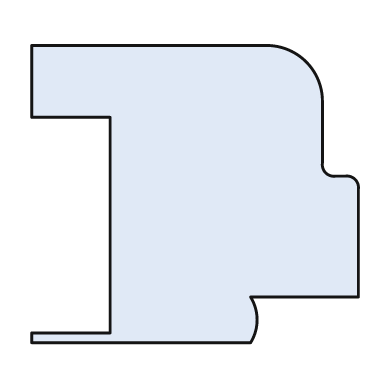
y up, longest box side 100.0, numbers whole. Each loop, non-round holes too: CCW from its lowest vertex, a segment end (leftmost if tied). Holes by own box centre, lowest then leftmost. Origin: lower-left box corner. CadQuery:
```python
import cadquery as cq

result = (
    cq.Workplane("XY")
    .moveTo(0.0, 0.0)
    .lineTo(67.0, 0.0)
    .threePointArc((69.0, 7.0), (67.0, 14.0))
    .lineTo(100.0, 14.0)
    .lineTo(100.0, 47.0)
    .threePointArc((99.0, 50.0), (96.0, 51.0))
    .lineTo(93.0, 51.0)
    .threePointArc((90.0, 52.0), (89.0, 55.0))
    .lineTo(89.0, 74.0)
    .threePointArc((84.0, 86.0), (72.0, 91.0))
    .lineTo(0.0, 91.0)
    .lineTo(0.0, 69.0)
    .lineTo(24.0, 69.0)
    .lineTo(24.0, 3.0)
    .lineTo(0.0, 3.0)
    .close()
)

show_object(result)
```